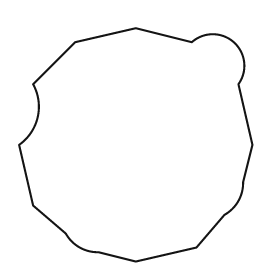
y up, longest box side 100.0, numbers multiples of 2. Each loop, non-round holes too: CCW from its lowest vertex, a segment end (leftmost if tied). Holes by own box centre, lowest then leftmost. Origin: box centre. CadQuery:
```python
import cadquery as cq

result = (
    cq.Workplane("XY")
    .moveTo(0.0, -50.0)
    .lineTo(26.0, -44.0)
    .lineTo(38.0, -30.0)
    .threePointArc((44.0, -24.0), (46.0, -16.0))
    .lineTo(50.0, 0.0)
    .lineTo(44.0, 26.0)
    .threePointArc((42.0, 44.0), (24.0, 44.0))
    .lineTo(0.0, 50.0)
    .lineTo(-26.0, 44.0)
    .lineTo(-44.0, 26.0)
    .threePointArc((-42.0, 12.0), (-50.0, 0.0))
    .lineTo(-44.0, -26.0)
    .lineTo(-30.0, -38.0)
    .threePointArc((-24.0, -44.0), (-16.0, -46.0))
    .close()
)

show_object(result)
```